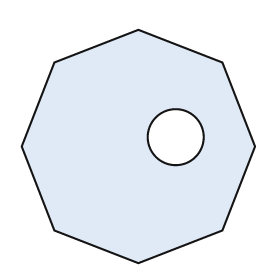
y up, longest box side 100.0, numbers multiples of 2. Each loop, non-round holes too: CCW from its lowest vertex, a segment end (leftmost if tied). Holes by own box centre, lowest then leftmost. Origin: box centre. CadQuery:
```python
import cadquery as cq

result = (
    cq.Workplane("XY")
    .moveTo(0.0, -50.0)
    .lineTo(36.0, -36.0)
    .lineTo(50.0, 0.0)
    .lineTo(36.0, 36.0)
    .lineTo(0.0, 50.0)
    .lineTo(-36.0, 36.0)
    .lineTo(-50.0, 0.0)
    .lineTo(-36.0, -36.0)
    .close()
    .moveTo(16.0, 4.0)
    .circle(12.0)
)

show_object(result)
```